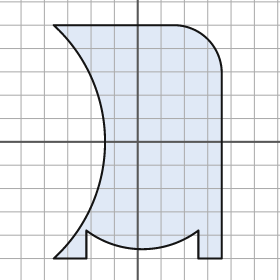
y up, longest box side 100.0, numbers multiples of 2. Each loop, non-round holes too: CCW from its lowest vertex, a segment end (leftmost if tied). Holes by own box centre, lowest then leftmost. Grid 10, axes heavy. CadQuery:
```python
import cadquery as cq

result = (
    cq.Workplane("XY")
    .moveTo(-36.0, -50.0)
    .lineTo(-22.0, -50.0)
    .lineTo(-22.0, -38.0)
    .threePointArc((2.0, -46.0), (26.0, -38.0))
    .lineTo(26.0, -50.0)
    .lineTo(36.0, -50.0)
    .lineTo(36.0, 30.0)
    .threePointArc((30.0, 44.0), (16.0, 50.0))
    .lineTo(-36.0, 50.0)
    .threePointArc((-14.0, 0.0), (-36.0, -50.0))
    .close()
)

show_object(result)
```